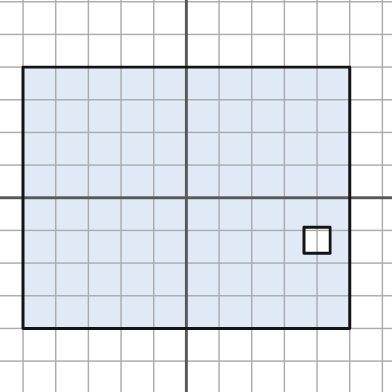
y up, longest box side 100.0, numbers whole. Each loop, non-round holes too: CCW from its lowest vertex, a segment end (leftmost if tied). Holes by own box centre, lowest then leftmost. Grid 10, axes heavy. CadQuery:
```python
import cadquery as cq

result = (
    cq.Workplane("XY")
    .moveTo(-50.0, -40.0)
    .lineTo(50.0, -40.0)
    .lineTo(50.0, 40.0)
    .lineTo(-50.0, 40.0)
    .close()
    .moveTo(36.0, -17.0)
    .lineTo(44.0, -17.0)
    .lineTo(44.0, -9.0)
    .lineTo(36.0, -9.0)
    .close()
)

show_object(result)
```